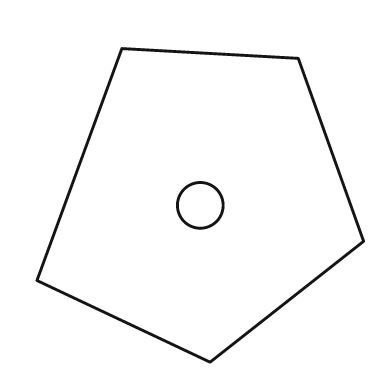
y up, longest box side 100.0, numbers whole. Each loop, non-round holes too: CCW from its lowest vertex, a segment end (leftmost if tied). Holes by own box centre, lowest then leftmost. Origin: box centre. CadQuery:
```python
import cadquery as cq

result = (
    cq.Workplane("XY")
    .moveTo(3.0, -48.0)
    .lineTo(50.0, -11.0)
    .lineTo(30.0, 45.0)
    .lineTo(-24.0, 48.0)
    .lineTo(-50.0, -23.0)
    .close()
    .moveTo(0.0, 0.0)
    .circle(7.0)
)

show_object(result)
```